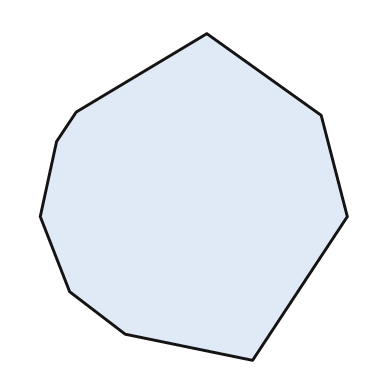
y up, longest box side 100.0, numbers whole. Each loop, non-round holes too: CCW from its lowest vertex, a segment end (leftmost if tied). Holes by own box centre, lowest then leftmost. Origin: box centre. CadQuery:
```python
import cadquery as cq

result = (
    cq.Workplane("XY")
    .moveTo(18.0, -50.0)
    .lineTo(47.0, -6.0)
    .lineTo(39.0, 25.0)
    .lineTo(4.0, 50.0)
    .lineTo(-36.0, 26.0)
    .lineTo(-42.0, 17.0)
    .lineTo(-47.0, -6.0)
    .lineTo(-38.0, -29.0)
    .lineTo(-21.0, -42.0)
    .close()
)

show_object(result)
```